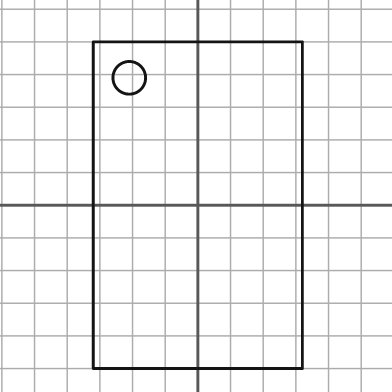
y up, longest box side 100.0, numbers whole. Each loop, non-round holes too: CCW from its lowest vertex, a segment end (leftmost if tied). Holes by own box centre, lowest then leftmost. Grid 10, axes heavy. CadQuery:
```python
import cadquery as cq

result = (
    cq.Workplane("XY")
    .moveTo(-32.0, -50.0)
    .lineTo(32.0, -50.0)
    .lineTo(32.0, 50.0)
    .lineTo(-32.0, 50.0)
    .close()
    .moveTo(-21.0, 39.0)
    .circle(5.0)
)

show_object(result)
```